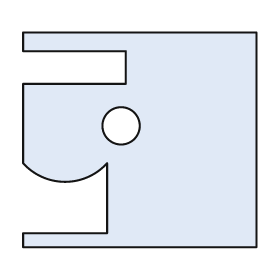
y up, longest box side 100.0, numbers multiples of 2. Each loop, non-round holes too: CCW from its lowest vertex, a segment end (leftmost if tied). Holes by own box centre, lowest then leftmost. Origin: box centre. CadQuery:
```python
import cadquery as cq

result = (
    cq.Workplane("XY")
    .moveTo(-50.0, -46.0)
    .lineTo(50.0, -46.0)
    .lineTo(50.0, 46.0)
    .lineTo(-50.0, 46.0)
    .lineTo(-50.0, 38.0)
    .lineTo(-6.0, 38.0)
    .lineTo(-6.0, 24.0)
    .lineTo(-50.0, 24.0)
    .lineTo(-50.0, -10.0)
    .threePointArc((-32.0, -18.0), (-14.0, -10.0))
    .lineTo(-14.0, -40.0)
    .lineTo(-50.0, -40.0)
    .close()
    .moveTo(-8.0, 6.0)
    .circle(8.0)
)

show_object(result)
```